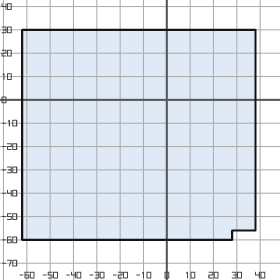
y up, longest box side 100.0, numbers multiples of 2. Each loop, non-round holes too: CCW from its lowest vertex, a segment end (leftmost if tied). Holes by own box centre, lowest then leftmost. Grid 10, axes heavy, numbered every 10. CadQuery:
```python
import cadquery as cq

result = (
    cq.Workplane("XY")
    .moveTo(-62.0, -60.0)
    .lineTo(28.0, -60.0)
    .lineTo(28.0, -56.0)
    .lineTo(38.0, -56.0)
    .lineTo(38.0, 30.0)
    .lineTo(-62.0, 30.0)
    .close()
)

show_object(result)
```